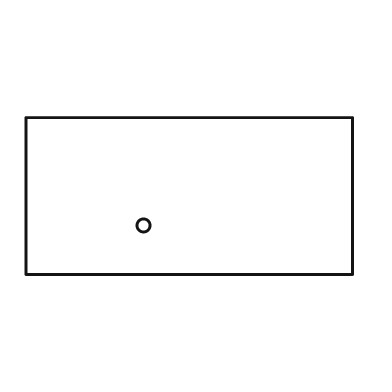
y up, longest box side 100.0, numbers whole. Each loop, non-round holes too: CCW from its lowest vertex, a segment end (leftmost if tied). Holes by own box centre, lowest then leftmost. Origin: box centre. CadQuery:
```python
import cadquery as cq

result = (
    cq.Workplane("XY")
    .moveTo(-50.0, -24.0)
    .lineTo(50.0, -24.0)
    .lineTo(50.0, 24.0)
    .lineTo(-50.0, 24.0)
    .close()
    .moveTo(-14.0, -9.0)
    .circle(2.0)
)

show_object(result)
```